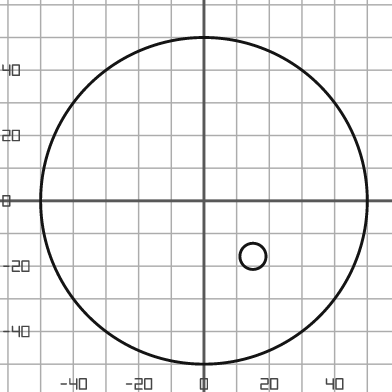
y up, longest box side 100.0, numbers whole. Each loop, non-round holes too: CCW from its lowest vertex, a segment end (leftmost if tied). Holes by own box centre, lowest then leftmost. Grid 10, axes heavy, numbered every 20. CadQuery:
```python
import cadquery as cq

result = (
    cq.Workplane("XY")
    .moveTo(0.0, 0.0)
    .circle(50.0)
    .moveTo(15.0, -17.0)
    .circle(4.0)
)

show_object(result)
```